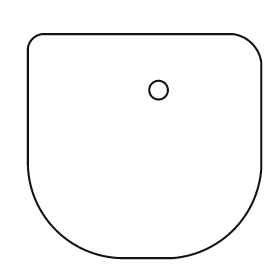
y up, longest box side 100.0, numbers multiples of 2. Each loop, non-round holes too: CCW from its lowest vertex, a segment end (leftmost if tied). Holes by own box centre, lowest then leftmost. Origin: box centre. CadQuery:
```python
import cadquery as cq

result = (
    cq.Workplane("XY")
    .moveTo(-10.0, -48.0)
    .lineTo(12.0, -48.0)
    .threePointArc((38.0, -36.0), (50.0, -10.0))
    .lineTo(50.0, 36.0)
    .threePointArc((46.0, 44.0), (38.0, 48.0))
    .lineTo(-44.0, 48.0)
    .threePointArc((-48.0, 46.0), (-50.0, 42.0))
    .lineTo(-50.0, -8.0)
    .threePointArc((-38.0, -36.0), (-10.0, -48.0))
    .close()
    .moveTo(6.0, 24.0)
    .circle(4.0)
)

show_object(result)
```